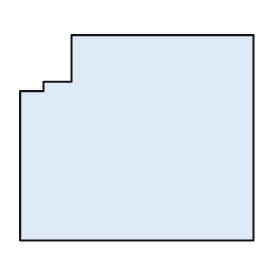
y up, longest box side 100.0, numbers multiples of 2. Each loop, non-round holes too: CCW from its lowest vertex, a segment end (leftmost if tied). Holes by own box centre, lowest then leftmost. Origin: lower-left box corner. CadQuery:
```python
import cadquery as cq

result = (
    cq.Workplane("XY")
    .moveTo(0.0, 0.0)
    .lineTo(100.0, 0.0)
    .lineTo(100.0, 88.0)
    .lineTo(22.0, 88.0)
    .lineTo(22.0, 68.0)
    .lineTo(10.0, 68.0)
    .lineTo(10.0, 64.0)
    .lineTo(0.0, 64.0)
    .close()
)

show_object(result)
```